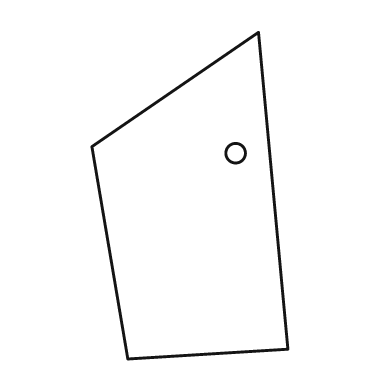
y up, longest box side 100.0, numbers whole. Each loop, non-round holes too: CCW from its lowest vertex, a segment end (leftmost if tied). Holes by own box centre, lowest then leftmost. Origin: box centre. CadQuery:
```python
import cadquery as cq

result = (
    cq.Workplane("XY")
    .moveTo(-19.0, -50.0)
    .lineTo(30.0, -47.0)
    .lineTo(21.0, 50.0)
    .lineTo(-30.0, 15.0)
    .close()
    .moveTo(14.0, 13.0)
    .circle(3.0)
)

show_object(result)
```